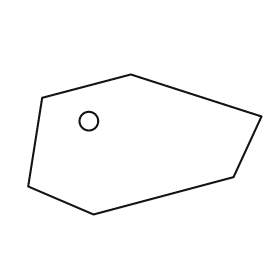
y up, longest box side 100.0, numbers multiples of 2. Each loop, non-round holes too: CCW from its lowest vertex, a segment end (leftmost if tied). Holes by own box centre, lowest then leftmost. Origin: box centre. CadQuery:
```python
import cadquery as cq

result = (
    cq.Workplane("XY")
    .moveTo(-22.0, -30.0)
    .lineTo(38.0, -14.0)
    .lineTo(50.0, 12.0)
    .lineTo(-6.0, 30.0)
    .lineTo(-44.0, 20.0)
    .lineTo(-50.0, -18.0)
    .close()
    .moveTo(-24.0, 10.0)
    .circle(4.0)
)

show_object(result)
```